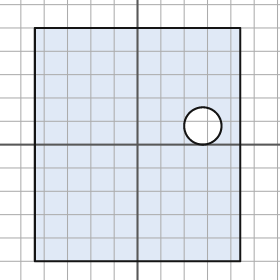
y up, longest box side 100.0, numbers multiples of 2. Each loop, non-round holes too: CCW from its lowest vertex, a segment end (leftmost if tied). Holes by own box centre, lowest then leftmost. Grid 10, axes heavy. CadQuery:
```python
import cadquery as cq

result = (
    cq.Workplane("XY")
    .moveTo(-44.0, -50.0)
    .lineTo(44.0, -50.0)
    .lineTo(44.0, 50.0)
    .lineTo(-44.0, 50.0)
    .close()
    .moveTo(28.0, 8.0)
    .circle(8.0)
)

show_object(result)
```